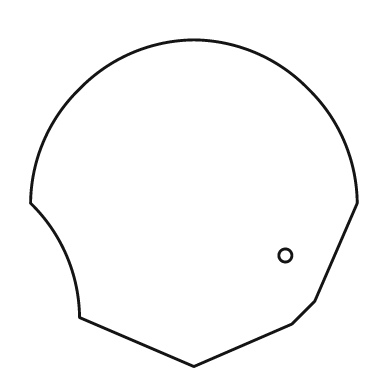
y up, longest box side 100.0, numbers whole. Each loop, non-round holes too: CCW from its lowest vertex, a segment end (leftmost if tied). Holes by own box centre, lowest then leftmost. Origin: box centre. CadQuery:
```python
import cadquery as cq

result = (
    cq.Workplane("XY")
    .moveTo(0.0, -50.0)
    .lineTo(30.0, -37.0)
    .lineTo(37.0, -30.0)
    .lineTo(50.0, 0.0)
    .threePointArc((46.0, 19.0), (35.0, 35.0))
    .threePointArc((19.0, 46.0), (0.0, 50.0))
    .threePointArc((-19.0, 46.0), (-35.0, 35.0))
    .threePointArc((-46.0, 19.0), (-50.0, 0.0))
    .threePointArc((-39.0, -16.0), (-35.0, -35.0))
    .close()
    .moveTo(28.0, -16.0)
    .circle(2.0)
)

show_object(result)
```